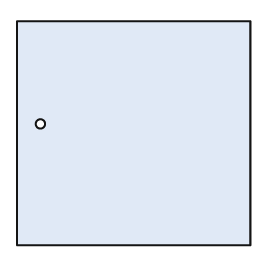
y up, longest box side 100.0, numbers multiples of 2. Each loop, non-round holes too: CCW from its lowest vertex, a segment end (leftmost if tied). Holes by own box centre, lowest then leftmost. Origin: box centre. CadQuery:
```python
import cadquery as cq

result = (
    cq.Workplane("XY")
    .moveTo(-50.0, -48.0)
    .lineTo(50.0, -48.0)
    .lineTo(50.0, 48.0)
    .lineTo(-50.0, 48.0)
    .close()
    .moveTo(-40.0, 4.0)
    .circle(2.0)
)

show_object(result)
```